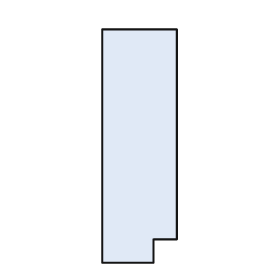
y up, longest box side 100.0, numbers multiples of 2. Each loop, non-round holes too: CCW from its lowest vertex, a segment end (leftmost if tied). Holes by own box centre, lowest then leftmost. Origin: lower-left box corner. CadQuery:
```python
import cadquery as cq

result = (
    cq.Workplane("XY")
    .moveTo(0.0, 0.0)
    .lineTo(22.0, 0.0)
    .lineTo(22.0, 10.0)
    .lineTo(32.0, 10.0)
    .lineTo(32.0, 100.0)
    .lineTo(0.0, 100.0)
    .close()
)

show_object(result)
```